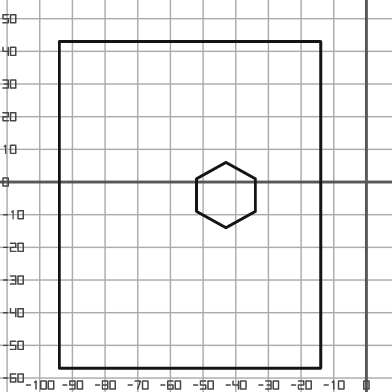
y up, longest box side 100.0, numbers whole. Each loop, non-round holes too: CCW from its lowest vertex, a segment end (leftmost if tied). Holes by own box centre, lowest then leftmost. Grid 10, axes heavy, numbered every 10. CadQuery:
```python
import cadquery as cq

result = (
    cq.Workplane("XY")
    .moveTo(-94.0, -57.0)
    .lineTo(-14.0, -57.0)
    .lineTo(-14.0, 43.0)
    .lineTo(-94.0, 43.0)
    .close()
    .moveTo(-43.0, -14.0)
    .lineTo(-34.0, -9.0)
    .lineTo(-34.0, 1.0)
    .lineTo(-43.0, 6.0)
    .lineTo(-52.0, 1.0)
    .lineTo(-52.0, -9.0)
    .close()
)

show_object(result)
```